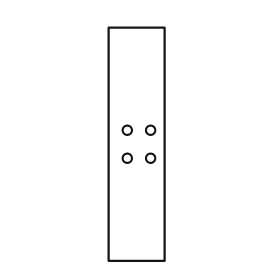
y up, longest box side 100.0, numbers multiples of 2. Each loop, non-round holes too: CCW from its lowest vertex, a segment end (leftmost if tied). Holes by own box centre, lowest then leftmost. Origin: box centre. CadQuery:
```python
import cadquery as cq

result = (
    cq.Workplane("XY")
    .moveTo(-12.0, -50.0)
    .lineTo(12.0, -50.0)
    .lineTo(12.0, 50.0)
    .lineTo(-12.0, 50.0)
    .close()
    .moveTo(-4.0, -6.0)
    .circle(2.0)
    .moveTo(6.0, -6.0)
    .circle(2.0)
    .moveTo(-4.0, 6.0)
    .circle(2.0)
    .moveTo(6.0, 6.0)
    .circle(2.0)
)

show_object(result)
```